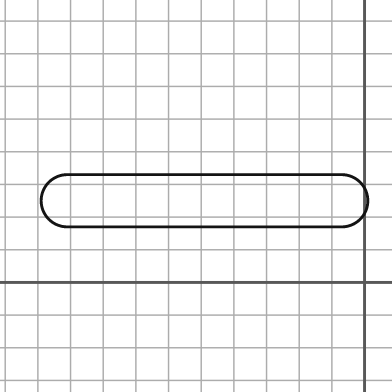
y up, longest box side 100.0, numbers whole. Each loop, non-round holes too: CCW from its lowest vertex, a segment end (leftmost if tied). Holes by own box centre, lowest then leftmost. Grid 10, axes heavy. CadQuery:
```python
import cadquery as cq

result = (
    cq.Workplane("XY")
    .moveTo(-91.0, 17.0)
    .lineTo(-7.0, 17.0)
    .threePointArc((1.0, 25.0), (-7.0, 33.0))
    .lineTo(-91.0, 33.0)
    .threePointArc((-99.0, 25.0), (-91.0, 17.0))
    .close()
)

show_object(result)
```